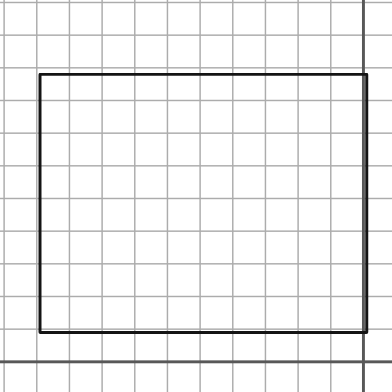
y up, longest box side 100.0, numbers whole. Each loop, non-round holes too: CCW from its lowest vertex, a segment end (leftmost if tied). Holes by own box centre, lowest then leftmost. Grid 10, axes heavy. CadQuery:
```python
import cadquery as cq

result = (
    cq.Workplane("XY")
    .moveTo(-99.0, 9.0)
    .lineTo(1.0, 9.0)
    .lineTo(1.0, 88.0)
    .lineTo(-99.0, 88.0)
    .close()
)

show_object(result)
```